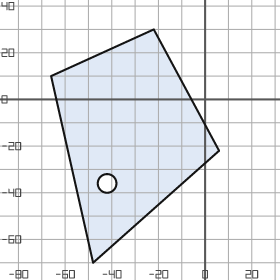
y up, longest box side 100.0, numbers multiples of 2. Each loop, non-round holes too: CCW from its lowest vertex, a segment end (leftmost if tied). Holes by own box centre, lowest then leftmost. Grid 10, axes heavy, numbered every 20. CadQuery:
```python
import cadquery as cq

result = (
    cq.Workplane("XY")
    .moveTo(-48.0, -70.0)
    .lineTo(6.0, -22.0)
    .lineTo(-22.0, 30.0)
    .lineTo(-66.0, 10.0)
    .close()
    .moveTo(-42.0, -36.0)
    .circle(4.0)
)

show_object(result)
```